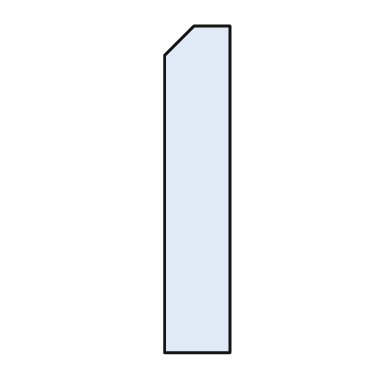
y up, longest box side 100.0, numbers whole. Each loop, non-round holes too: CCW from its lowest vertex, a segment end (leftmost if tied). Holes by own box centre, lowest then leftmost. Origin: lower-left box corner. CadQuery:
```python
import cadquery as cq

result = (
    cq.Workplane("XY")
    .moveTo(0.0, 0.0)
    .lineTo(20.0, 0.0)
    .lineTo(20.0, 100.0)
    .lineTo(9.0, 100.0)
    .lineTo(0.0, 91.0)
    .close()
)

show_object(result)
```